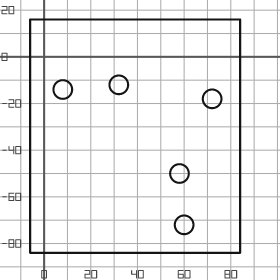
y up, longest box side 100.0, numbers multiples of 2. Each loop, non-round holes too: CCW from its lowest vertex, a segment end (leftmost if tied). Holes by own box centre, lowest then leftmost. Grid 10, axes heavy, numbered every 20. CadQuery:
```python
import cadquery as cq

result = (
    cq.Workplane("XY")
    .moveTo(-6.0, -84.0)
    .lineTo(84.0, -84.0)
    .lineTo(84.0, 16.0)
    .lineTo(-6.0, 16.0)
    .close()
    .moveTo(60.0, -72.0)
    .circle(4.0)
    .moveTo(58.0, -50.0)
    .circle(4.0)
    .moveTo(72.0, -18.0)
    .circle(4.0)
    .moveTo(8.0, -14.0)
    .circle(4.0)
    .moveTo(32.0, -12.0)
    .circle(4.0)
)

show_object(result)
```